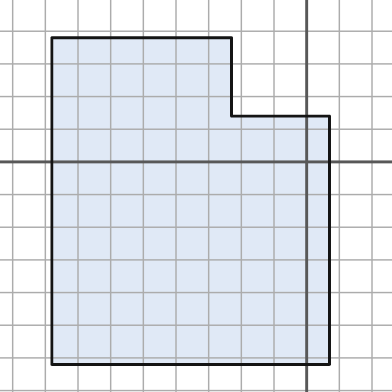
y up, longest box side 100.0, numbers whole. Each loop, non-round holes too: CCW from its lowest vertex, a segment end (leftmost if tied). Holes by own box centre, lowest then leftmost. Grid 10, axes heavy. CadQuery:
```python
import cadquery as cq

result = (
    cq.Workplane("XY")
    .moveTo(-78.0, -62.0)
    .lineTo(7.0, -62.0)
    .lineTo(7.0, 14.0)
    .lineTo(-23.0, 14.0)
    .lineTo(-23.0, 38.0)
    .lineTo(-78.0, 38.0)
    .close()
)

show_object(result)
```